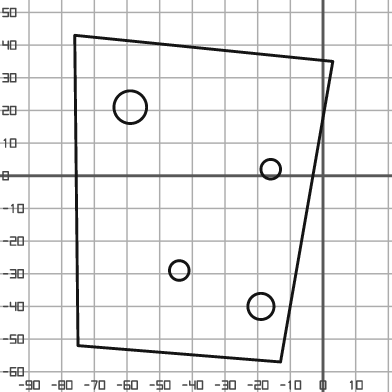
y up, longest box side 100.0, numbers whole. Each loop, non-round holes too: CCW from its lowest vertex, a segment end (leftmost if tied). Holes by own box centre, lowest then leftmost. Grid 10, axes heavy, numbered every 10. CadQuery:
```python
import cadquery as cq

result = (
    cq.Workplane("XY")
    .moveTo(-13.0, -57.0)
    .lineTo(3.0, 35.0)
    .lineTo(-76.0, 43.0)
    .lineTo(-75.0, -52.0)
    .close()
    .moveTo(-19.0, -40.0)
    .circle(4.0)
    .moveTo(-44.0, -29.0)
    .circle(3.0)
    .moveTo(-16.0, 2.0)
    .circle(3.0)
    .moveTo(-59.0, 21.0)
    .circle(5.0)
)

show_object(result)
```